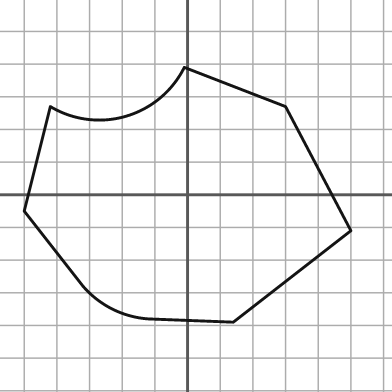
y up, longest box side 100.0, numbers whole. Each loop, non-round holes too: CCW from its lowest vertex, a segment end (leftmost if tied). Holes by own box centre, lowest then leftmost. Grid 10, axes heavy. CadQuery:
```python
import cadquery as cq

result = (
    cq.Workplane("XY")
    .moveTo(14.0, -39.0)
    .lineTo(50.0, -11.0)
    .lineTo(30.0, 27.0)
    .lineTo(-1.0, 39.0)
    .threePointArc((-19.0, 24.0), (-42.0, 27.0))
    .lineTo(-50.0, -5.0)
    .lineTo(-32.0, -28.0)
    .threePointArc((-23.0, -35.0), (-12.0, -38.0))
    .close()
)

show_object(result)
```